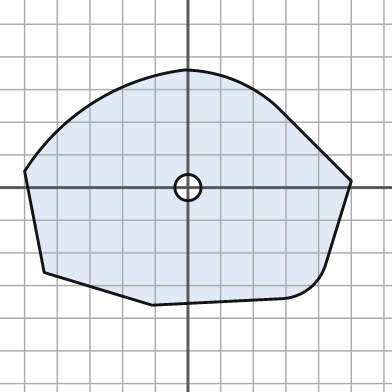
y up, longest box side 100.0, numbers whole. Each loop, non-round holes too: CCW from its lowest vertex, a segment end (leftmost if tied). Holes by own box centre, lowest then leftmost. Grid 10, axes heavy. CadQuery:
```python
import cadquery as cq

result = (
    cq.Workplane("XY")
    .moveTo(-11.0, -36.0)
    .lineTo(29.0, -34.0)
    .threePointArc((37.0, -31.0), (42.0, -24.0))
    .lineTo(50.0, 2.0)
    .lineTo(27.0, 25.0)
    .threePointArc((14.0, 33.0), (-1.0, 36.0))
    .threePointArc((-29.0, 26.0), (-50.0, 5.0))
    .lineTo(-44.0, -26.0)
    .close()
    .moveTo(0.0, 0.0)
    .circle(4.0)
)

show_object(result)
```